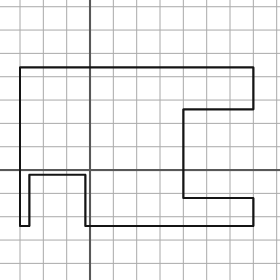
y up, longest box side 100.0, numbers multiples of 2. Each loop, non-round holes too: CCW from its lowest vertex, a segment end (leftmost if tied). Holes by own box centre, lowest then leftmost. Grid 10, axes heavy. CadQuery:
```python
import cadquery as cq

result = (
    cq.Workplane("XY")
    .moveTo(-30.0, -24.0)
    .lineTo(-26.0, -24.0)
    .lineTo(-26.0, -2.0)
    .lineTo(-2.0, -2.0)
    .lineTo(-2.0, -24.0)
    .lineTo(70.0, -24.0)
    .lineTo(70.0, -12.0)
    .lineTo(40.0, -12.0)
    .lineTo(40.0, 26.0)
    .lineTo(70.0, 26.0)
    .lineTo(70.0, 44.0)
    .lineTo(-30.0, 44.0)
    .close()
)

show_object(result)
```